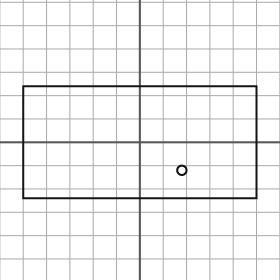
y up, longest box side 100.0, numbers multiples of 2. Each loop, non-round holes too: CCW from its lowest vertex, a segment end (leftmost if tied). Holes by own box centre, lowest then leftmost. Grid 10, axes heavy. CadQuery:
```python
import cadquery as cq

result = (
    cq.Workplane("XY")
    .moveTo(-50.0, -24.0)
    .lineTo(50.0, -24.0)
    .lineTo(50.0, 24.0)
    .lineTo(-50.0, 24.0)
    .close()
    .moveTo(18.0, -12.0)
    .circle(2.0)
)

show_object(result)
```